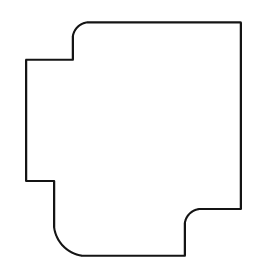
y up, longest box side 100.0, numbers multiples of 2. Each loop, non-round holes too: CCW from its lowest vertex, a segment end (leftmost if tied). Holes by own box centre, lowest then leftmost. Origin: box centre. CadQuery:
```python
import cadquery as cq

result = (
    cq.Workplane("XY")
    .moveTo(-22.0, -50.0)
    .lineTo(22.0, -50.0)
    .lineTo(22.0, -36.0)
    .threePointArc((24.0, -32.0), (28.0, -30.0))
    .lineTo(46.0, -30.0)
    .lineTo(46.0, 50.0)
    .lineTo(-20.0, 50.0)
    .threePointArc((-24.0, 48.0), (-26.0, 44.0))
    .lineTo(-26.0, 34.0)
    .lineTo(-46.0, 34.0)
    .lineTo(-46.0, -18.0)
    .lineTo(-34.0, -18.0)
    .lineTo(-34.0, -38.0)
    .threePointArc((-30.0, -46.0), (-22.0, -50.0))
    .close()
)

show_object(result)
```